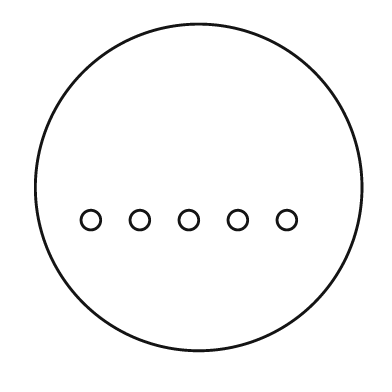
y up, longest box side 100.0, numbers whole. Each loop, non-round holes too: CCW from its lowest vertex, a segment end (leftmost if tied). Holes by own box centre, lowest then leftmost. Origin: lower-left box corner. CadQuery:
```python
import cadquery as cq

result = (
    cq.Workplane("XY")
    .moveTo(50.0, 50.0)
    .circle(50.0)
    .moveTo(17.0, 40.0)
    .circle(3.0)
    .moveTo(32.0, 40.0)
    .circle(3.0)
    .moveTo(47.0, 40.0)
    .circle(3.0)
    .moveTo(62.0, 40.0)
    .circle(3.0)
    .moveTo(77.0, 40.0)
    .circle(3.0)
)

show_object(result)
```